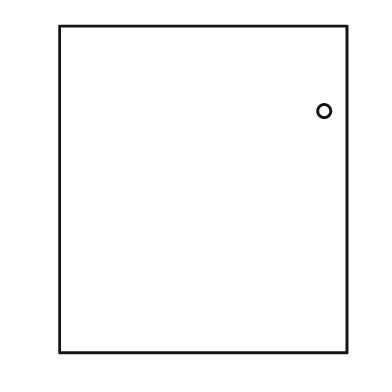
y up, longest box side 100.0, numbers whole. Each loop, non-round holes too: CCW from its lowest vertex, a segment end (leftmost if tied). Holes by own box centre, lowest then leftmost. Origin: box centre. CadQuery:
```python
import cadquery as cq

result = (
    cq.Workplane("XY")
    .moveTo(-44.0, -50.0)
    .lineTo(44.0, -50.0)
    .lineTo(44.0, 50.0)
    .lineTo(-44.0, 50.0)
    .close()
    .moveTo(37.0, 24.0)
    .circle(2.0)
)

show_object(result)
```